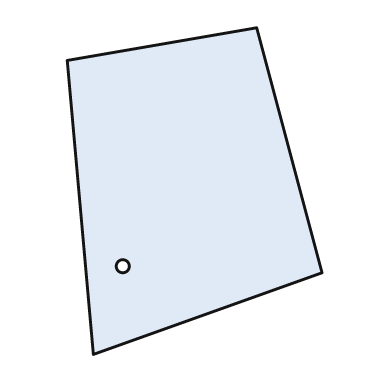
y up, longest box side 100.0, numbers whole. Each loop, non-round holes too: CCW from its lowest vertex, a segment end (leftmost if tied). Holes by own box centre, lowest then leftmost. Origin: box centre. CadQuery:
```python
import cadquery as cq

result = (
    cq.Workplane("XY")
    .moveTo(-31.0, -50.0)
    .lineTo(39.0, -25.0)
    .lineTo(19.0, 50.0)
    .lineTo(-39.0, 40.0)
    .close()
    .moveTo(-22.0, -23.0)
    .circle(2.0)
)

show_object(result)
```